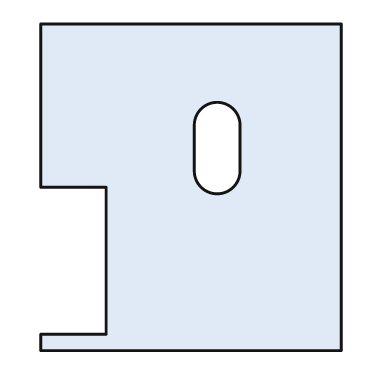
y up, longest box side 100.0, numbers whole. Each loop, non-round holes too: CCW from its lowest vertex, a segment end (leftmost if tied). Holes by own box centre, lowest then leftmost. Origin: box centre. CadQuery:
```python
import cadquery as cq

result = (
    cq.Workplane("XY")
    .moveTo(-46.0, -50.0)
    .lineTo(46.0, -50.0)
    .lineTo(46.0, 50.0)
    .lineTo(-46.0, 50.0)
    .lineTo(-46.0, 0.0)
    .lineTo(-26.0, 0.0)
    .lineTo(-26.0, -45.0)
    .lineTo(-46.0, -45.0)
    .close()
    .moveTo(1.0, 5.0)
    .threePointArc((8.0, -2.0), (15.0, 5.0))
    .lineTo(15.0, 19.0)
    .threePointArc((8.0, 26.0), (1.0, 19.0))
    .close()
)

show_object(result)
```